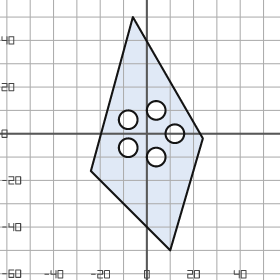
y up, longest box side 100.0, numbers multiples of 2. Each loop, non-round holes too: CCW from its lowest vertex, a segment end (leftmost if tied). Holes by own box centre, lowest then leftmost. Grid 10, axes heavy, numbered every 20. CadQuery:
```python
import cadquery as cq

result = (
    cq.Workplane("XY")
    .moveTo(10.0, -50.0)
    .lineTo(24.0, -2.0)
    .lineTo(-6.0, 50.0)
    .lineTo(-24.0, -16.0)
    .close()
    .moveTo(4.0, -10.0)
    .circle(4.0)
    .moveTo(-8.0, -6.0)
    .circle(4.0)
    .moveTo(12.0, 0.0)
    .circle(4.0)
    .moveTo(-8.0, 6.0)
    .circle(4.0)
    .moveTo(4.0, 10.0)
    .circle(4.0)
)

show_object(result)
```